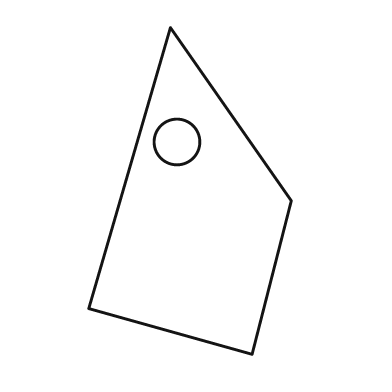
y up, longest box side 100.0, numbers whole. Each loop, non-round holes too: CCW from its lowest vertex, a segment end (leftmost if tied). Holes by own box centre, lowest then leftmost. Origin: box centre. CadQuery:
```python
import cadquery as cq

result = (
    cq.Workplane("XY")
    .moveTo(19.0, -50.0)
    .lineTo(31.0, -3.0)
    .lineTo(-6.0, 50.0)
    .lineTo(-31.0, -36.0)
    .close()
    .moveTo(-4.0, 15.0)
    .circle(7.0)
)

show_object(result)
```